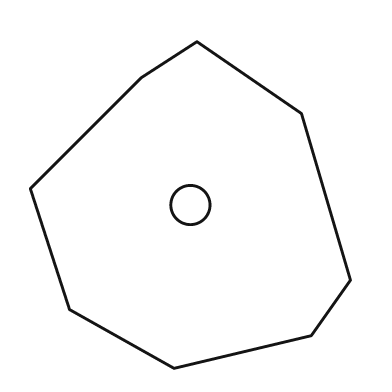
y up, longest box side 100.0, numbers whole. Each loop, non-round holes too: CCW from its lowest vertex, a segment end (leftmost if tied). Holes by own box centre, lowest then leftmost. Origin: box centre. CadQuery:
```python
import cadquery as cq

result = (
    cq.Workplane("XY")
    .moveTo(-5.0, -50.0)
    .lineTo(37.0, -40.0)
    .lineTo(49.0, -23.0)
    .lineTo(34.0, 28.0)
    .lineTo(2.0, 50.0)
    .lineTo(-15.0, 39.0)
    .lineTo(-49.0, 5.0)
    .lineTo(-37.0, -32.0)
    .close()
    .moveTo(0.0, 0.0)
    .circle(6.0)
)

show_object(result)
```